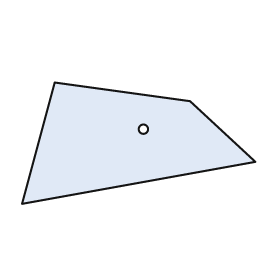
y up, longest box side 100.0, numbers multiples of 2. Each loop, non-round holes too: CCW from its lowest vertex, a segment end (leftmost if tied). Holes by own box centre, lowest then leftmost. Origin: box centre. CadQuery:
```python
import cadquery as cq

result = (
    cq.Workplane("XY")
    .moveTo(-50.0, -26.0)
    .lineTo(50.0, -8.0)
    .lineTo(22.0, 18.0)
    .lineTo(-36.0, 26.0)
    .close()
    .moveTo(2.0, 6.0)
    .circle(2.0)
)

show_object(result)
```